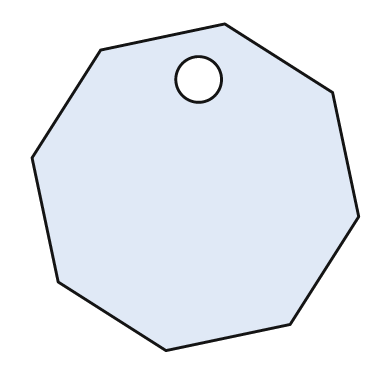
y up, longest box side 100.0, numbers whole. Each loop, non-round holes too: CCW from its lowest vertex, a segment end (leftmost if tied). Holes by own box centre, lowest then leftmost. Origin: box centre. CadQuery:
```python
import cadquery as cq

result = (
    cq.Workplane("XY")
    .moveTo(-9.0, -50.0)
    .lineTo(29.0, -42.0)
    .lineTo(50.0, -9.0)
    .lineTo(42.0, 29.0)
    .lineTo(9.0, 50.0)
    .lineTo(-29.0, 42.0)
    .lineTo(-50.0, 9.0)
    .lineTo(-42.0, -29.0)
    .close()
    .moveTo(1.0, 33.0)
    .circle(7.0)
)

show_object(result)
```